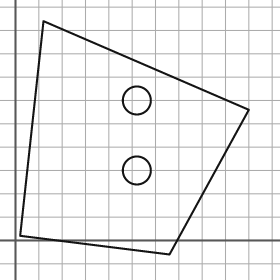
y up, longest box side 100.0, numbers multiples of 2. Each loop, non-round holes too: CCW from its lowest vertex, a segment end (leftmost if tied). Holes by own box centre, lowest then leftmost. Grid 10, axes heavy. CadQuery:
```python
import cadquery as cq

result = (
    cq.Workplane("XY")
    .moveTo(66.0, -6.0)
    .lineTo(100.0, 56.0)
    .lineTo(12.0, 94.0)
    .lineTo(2.0, 2.0)
    .close()
    .moveTo(52.0, 30.0)
    .circle(6.0)
    .moveTo(52.0, 60.0)
    .circle(6.0)
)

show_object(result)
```